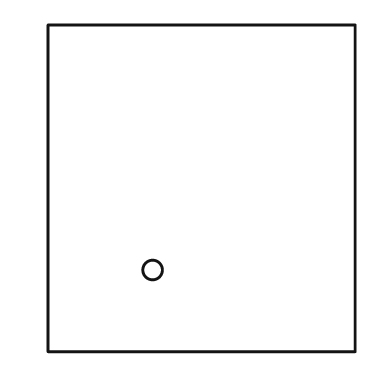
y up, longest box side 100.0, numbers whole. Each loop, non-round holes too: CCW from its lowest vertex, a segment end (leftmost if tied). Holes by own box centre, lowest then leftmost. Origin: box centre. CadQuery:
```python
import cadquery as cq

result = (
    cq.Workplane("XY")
    .moveTo(-47.0, -50.0)
    .lineTo(47.0, -50.0)
    .lineTo(47.0, 50.0)
    .lineTo(-47.0, 50.0)
    .close()
    .moveTo(-15.0, -25.0)
    .circle(3.0)
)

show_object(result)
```